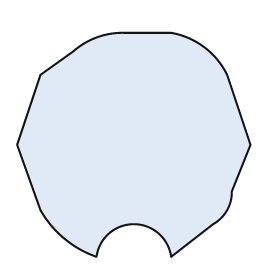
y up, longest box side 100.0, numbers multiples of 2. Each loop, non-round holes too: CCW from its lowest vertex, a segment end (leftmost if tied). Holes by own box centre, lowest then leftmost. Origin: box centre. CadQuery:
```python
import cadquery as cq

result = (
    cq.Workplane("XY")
    .moveTo(-16.0, -48.0)
    .threePointArc((0.0, -34.0), (16.0, -48.0))
    .lineTo(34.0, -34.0)
    .threePointArc((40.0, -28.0), (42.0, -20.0))
    .lineTo(50.0, 0.0)
    .lineTo(40.0, 30.0)
    .threePointArc((30.0, 42.0), (16.0, 48.0))
    .lineTo(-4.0, 48.0)
    .threePointArc((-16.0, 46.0), (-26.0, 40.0))
    .lineTo(-40.0, 30.0)
    .lineTo(-50.0, 0.0)
    .lineTo(-40.0, -28.0)
    .threePointArc((-30.0, -40.0), (-16.0, -48.0))
    .close()
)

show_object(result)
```